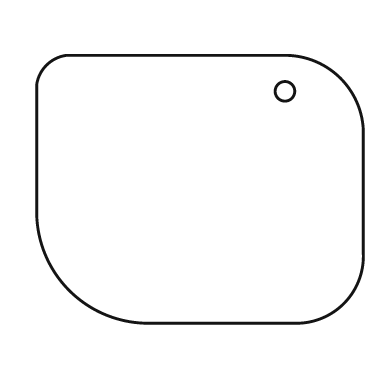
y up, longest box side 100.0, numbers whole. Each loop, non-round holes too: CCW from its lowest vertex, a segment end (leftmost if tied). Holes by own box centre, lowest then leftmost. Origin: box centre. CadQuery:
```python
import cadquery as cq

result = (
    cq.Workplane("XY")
    .moveTo(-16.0, -41.0)
    .lineTo(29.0, -41.0)
    .threePointArc((44.0, -35.0), (50.0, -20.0))
    .lineTo(50.0, 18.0)
    .threePointArc((43.0, 34.0), (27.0, 41.0))
    .lineTo(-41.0, 41.0)
    .threePointArc((-47.0, 38.0), (-50.0, 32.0))
    .lineTo(-50.0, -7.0)
    .threePointArc((-40.0, -31.0), (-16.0, -41.0))
    .close()
    .moveTo(26.0, 30.0)
    .circle(3.0)
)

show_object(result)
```